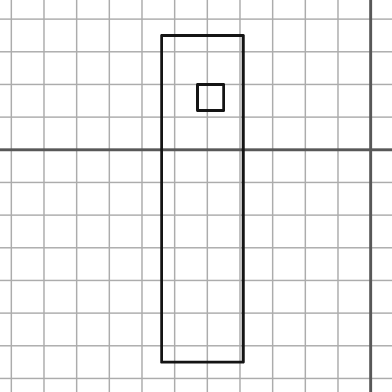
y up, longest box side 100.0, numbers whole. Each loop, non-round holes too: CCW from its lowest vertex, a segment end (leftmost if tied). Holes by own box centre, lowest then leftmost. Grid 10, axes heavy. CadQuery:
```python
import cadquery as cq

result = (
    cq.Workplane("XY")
    .moveTo(-64.0, -65.0)
    .lineTo(-39.0, -65.0)
    .lineTo(-39.0, 35.0)
    .lineTo(-64.0, 35.0)
    .close()
    .moveTo(-53.0, 12.0)
    .lineTo(-45.0, 12.0)
    .lineTo(-45.0, 20.0)
    .lineTo(-53.0, 20.0)
    .close()
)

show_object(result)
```